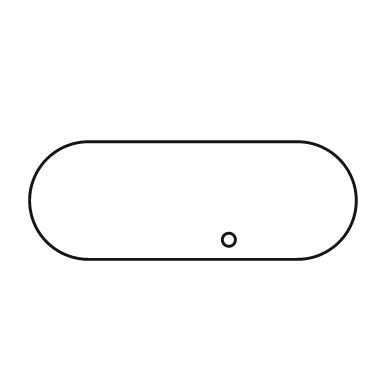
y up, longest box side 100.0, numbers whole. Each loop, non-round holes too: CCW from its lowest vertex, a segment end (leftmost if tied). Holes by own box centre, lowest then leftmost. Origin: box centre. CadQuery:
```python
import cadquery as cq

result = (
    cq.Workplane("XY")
    .moveTo(-32.0, -18.0)
    .lineTo(32.0, -18.0)
    .threePointArc((50.0, 0.0), (32.0, 18.0))
    .lineTo(-32.0, 18.0)
    .threePointArc((-50.0, 0.0), (-32.0, -18.0))
    .close()
    .moveTo(11.0, -12.0)
    .circle(2.0)
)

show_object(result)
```